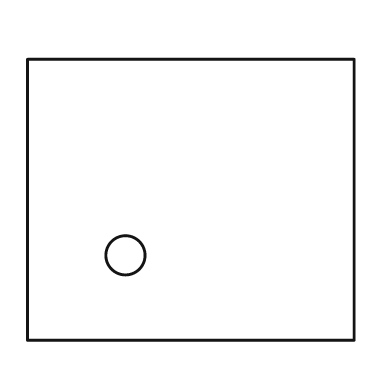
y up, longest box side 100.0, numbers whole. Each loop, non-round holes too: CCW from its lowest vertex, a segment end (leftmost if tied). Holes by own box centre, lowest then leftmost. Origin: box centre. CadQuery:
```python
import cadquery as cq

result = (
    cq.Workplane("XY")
    .moveTo(-50.0, -43.0)
    .lineTo(50.0, -43.0)
    .lineTo(50.0, 43.0)
    .lineTo(-50.0, 43.0)
    .close()
    .moveTo(-20.0, -17.0)
    .circle(6.0)
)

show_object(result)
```